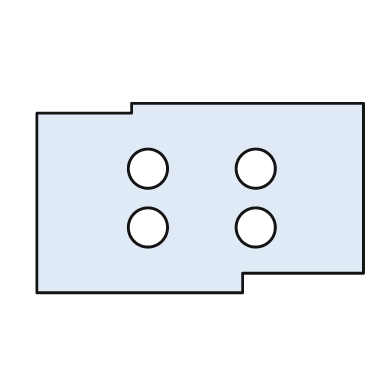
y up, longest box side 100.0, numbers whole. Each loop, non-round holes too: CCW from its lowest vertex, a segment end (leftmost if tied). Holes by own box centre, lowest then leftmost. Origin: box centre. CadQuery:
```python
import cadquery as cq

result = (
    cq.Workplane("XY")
    .moveTo(-50.0, -29.0)
    .lineTo(13.0, -29.0)
    .lineTo(13.0, -23.0)
    .lineTo(50.0, -23.0)
    .lineTo(50.0, 29.0)
    .lineTo(-21.0, 29.0)
    .lineTo(-21.0, 26.0)
    .lineTo(-50.0, 26.0)
    .close()
    .moveTo(-16.0, -9.0)
    .circle(6.0)
    .moveTo(17.0, -9.0)
    .circle(6.0)
    .moveTo(-16.0, 9.0)
    .circle(6.0)
    .moveTo(17.0, 9.0)
    .circle(6.0)
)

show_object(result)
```